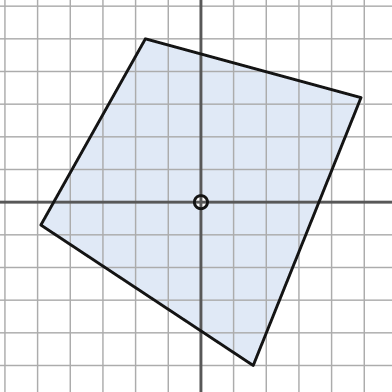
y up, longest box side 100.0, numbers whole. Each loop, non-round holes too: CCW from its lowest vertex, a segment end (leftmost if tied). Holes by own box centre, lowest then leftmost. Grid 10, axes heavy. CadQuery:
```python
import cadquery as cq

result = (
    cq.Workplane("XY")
    .moveTo(16.0, -50.0)
    .lineTo(49.0, 32.0)
    .lineTo(-17.0, 50.0)
    .lineTo(-49.0, -7.0)
    .close()
    .moveTo(0.0, 0.0)
    .circle(2.0)
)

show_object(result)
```